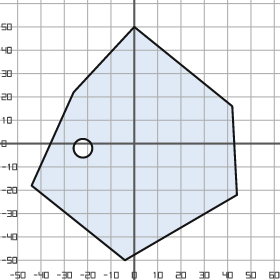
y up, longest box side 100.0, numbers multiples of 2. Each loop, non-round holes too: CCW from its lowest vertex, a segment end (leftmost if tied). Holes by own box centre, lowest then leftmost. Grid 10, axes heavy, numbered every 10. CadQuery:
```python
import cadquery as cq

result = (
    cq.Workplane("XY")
    .moveTo(-4.0, -50.0)
    .lineTo(44.0, -22.0)
    .lineTo(42.0, 16.0)
    .lineTo(0.0, 50.0)
    .lineTo(-26.0, 22.0)
    .lineTo(-44.0, -18.0)
    .close()
    .moveTo(-22.0, -2.0)
    .circle(4.0)
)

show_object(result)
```